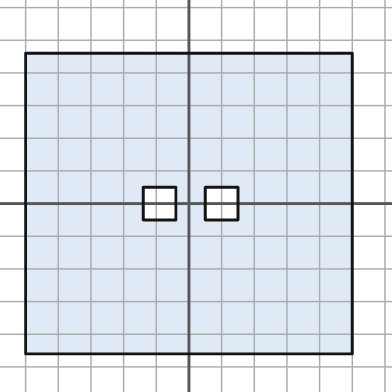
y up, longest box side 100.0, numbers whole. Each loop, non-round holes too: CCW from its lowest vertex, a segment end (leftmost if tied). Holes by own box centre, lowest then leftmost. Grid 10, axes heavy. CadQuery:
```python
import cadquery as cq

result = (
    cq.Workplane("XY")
    .moveTo(-50.0, -46.0)
    .lineTo(50.0, -46.0)
    .lineTo(50.0, 46.0)
    .lineTo(-50.0, 46.0)
    .close()
    .moveTo(-14.0, -5.0)
    .lineTo(-4.0, -5.0)
    .lineTo(-4.0, 5.0)
    .lineTo(-14.0, 5.0)
    .close()
    .moveTo(5.0, -5.0)
    .lineTo(15.0, -5.0)
    .lineTo(15.0, 5.0)
    .lineTo(5.0, 5.0)
    .close()
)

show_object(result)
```